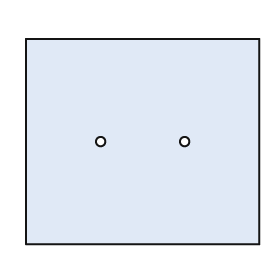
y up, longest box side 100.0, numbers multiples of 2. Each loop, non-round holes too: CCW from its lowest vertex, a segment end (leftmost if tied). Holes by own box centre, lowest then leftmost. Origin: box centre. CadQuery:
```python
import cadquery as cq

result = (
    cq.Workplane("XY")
    .moveTo(-50.0, -44.0)
    .lineTo(50.0, -44.0)
    .lineTo(50.0, 44.0)
    .lineTo(-50.0, 44.0)
    .close()
    .moveTo(-18.0, 0.0)
    .circle(2.0)
    .moveTo(18.0, 0.0)
    .circle(2.0)
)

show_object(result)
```